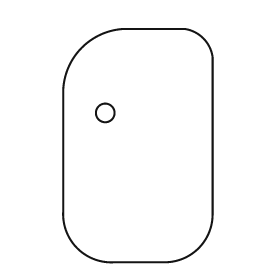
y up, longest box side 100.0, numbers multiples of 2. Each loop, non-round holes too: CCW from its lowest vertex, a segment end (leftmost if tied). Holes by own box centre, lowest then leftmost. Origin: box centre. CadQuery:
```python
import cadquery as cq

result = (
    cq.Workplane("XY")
    .moveTo(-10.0, -50.0)
    .lineTo(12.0, -50.0)
    .threePointArc((26.0, -44.0), (32.0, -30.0))
    .lineTo(32.0, 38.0)
    .threePointArc((28.0, 46.0), (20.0, 50.0))
    .lineTo(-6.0, 50.0)
    .threePointArc((-24.0, 42.0), (-32.0, 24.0))
    .lineTo(-32.0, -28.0)
    .threePointArc((-26.0, -44.0), (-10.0, -50.0))
    .close()
    .moveTo(-14.0, 14.0)
    .circle(4.0)
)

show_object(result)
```